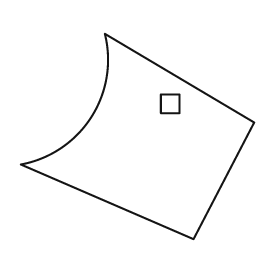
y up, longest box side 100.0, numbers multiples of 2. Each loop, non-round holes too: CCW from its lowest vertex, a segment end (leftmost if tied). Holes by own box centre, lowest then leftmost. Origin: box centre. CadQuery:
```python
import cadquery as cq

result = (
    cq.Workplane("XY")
    .moveTo(24.0, -44.0)
    .lineTo(50.0, 6.0)
    .lineTo(-14.0, 44.0)
    .threePointArc((-20.0, 8.0), (-50.0, -12.0))
    .close()
    .moveTo(10.0, 10.0)
    .lineTo(18.0, 10.0)
    .lineTo(18.0, 18.0)
    .lineTo(10.0, 18.0)
    .close()
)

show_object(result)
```